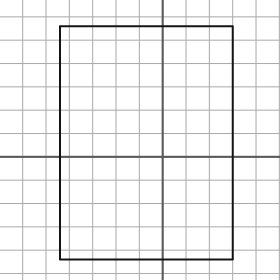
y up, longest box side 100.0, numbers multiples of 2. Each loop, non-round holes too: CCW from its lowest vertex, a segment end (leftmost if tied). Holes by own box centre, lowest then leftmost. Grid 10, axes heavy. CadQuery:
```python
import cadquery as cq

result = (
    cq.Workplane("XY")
    .moveTo(-44.0, -44.0)
    .lineTo(30.0, -44.0)
    .lineTo(30.0, 56.0)
    .lineTo(-44.0, 56.0)
    .close()
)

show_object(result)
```